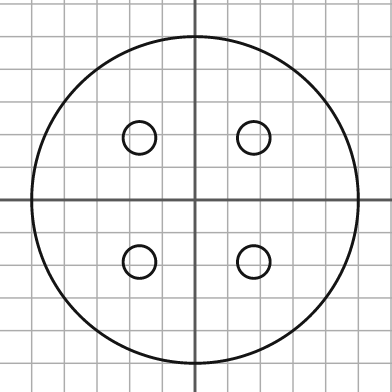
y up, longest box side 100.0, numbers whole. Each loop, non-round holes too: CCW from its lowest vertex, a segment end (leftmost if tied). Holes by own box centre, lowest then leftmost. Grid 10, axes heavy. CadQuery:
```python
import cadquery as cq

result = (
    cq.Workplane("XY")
    .moveTo(0.0, 0.0)
    .circle(50.0)
    .moveTo(-17.0, -19.0)
    .circle(5.0)
    .moveTo(18.0, -19.0)
    .circle(5.0)
    .moveTo(-17.0, 19.0)
    .circle(5.0)
    .moveTo(18.0, 19.0)
    .circle(5.0)
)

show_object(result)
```